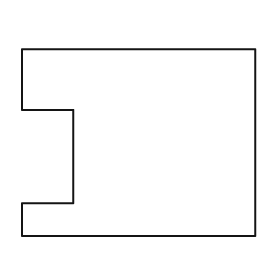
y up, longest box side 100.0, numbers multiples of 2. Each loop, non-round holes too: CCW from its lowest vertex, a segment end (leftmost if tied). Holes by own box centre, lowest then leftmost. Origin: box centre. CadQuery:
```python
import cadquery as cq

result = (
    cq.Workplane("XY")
    .moveTo(-50.0, -40.0)
    .lineTo(50.0, -40.0)
    .lineTo(50.0, 40.0)
    .lineTo(-50.0, 40.0)
    .lineTo(-50.0, 14.0)
    .lineTo(-28.0, 14.0)
    .lineTo(-28.0, -26.0)
    .lineTo(-50.0, -26.0)
    .close()
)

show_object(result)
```